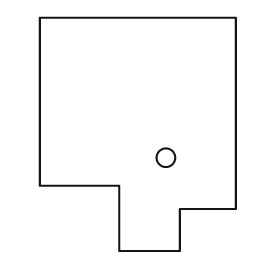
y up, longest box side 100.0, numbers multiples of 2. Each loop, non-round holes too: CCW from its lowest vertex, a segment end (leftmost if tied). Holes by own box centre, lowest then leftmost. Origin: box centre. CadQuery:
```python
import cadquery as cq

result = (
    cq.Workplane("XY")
    .moveTo(-8.0, -50.0)
    .lineTo(18.0, -50.0)
    .lineTo(18.0, -32.0)
    .lineTo(42.0, -32.0)
    .lineTo(42.0, 50.0)
    .lineTo(-42.0, 50.0)
    .lineTo(-42.0, -22.0)
    .lineTo(-8.0, -22.0)
    .close()
    .moveTo(12.0, -10.0)
    .circle(4.0)
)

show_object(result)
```